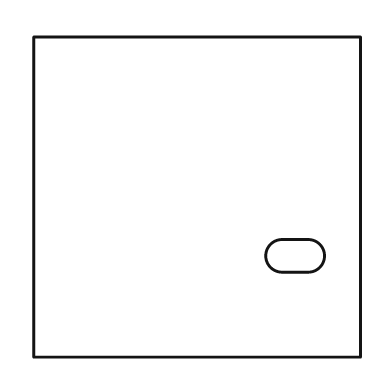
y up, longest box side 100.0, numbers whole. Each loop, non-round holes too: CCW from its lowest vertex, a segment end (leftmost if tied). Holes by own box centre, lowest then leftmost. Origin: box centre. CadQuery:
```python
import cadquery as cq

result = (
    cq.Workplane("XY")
    .moveTo(-50.0, -49.0)
    .lineTo(50.0, -49.0)
    .lineTo(50.0, 49.0)
    .lineTo(-50.0, 49.0)
    .close()
    .moveTo(26.0, -23.0)
    .lineTo(34.0, -23.0)
    .threePointArc((39.0, -18.0), (34.0, -13.0))
    .lineTo(26.0, -13.0)
    .threePointArc((21.0, -18.0), (26.0, -23.0))
    .close()
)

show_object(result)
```